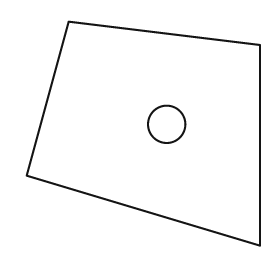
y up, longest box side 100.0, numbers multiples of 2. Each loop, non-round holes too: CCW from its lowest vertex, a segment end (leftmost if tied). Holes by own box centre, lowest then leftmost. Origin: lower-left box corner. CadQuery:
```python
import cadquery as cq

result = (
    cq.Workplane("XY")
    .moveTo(100.0, 0.0)
    .lineTo(100.0, 86.0)
    .lineTo(18.0, 96.0)
    .lineTo(0.0, 30.0)
    .close()
    .moveTo(60.0, 52.0)
    .circle(8.0)
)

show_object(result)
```